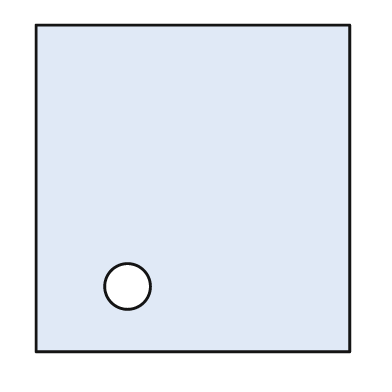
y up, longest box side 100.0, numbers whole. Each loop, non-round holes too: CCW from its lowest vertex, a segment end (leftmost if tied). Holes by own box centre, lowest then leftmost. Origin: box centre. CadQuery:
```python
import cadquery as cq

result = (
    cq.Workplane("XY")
    .moveTo(-48.0, -50.0)
    .lineTo(48.0, -50.0)
    .lineTo(48.0, 50.0)
    .lineTo(-48.0, 50.0)
    .close()
    .moveTo(-20.0, -30.0)
    .circle(7.0)
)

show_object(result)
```